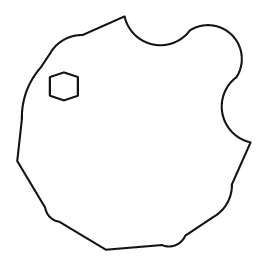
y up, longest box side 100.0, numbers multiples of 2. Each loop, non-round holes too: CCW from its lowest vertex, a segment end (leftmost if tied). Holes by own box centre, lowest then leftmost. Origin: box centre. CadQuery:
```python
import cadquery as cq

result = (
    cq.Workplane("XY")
    .moveTo(-12.0, -50.0)
    .lineTo(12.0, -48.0)
    .threePointArc((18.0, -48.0), (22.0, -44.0))
    .lineTo(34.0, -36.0)
    .threePointArc((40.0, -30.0), (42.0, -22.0))
    .lineTo(50.0, -4.0)
    .threePointArc((38.0, 8.0), (44.0, 24.0))
    .threePointArc((42.0, 42.0), (24.0, 44.0))
    .threePointArc((8.0, 38.0), (-4.0, 50.0))
    .lineTo(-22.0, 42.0)
    .threePointArc((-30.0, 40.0), (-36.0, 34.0))
    .lineTo(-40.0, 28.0)
    .threePointArc((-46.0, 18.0), (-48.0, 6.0))
    .lineTo(-50.0, -12.0)
    .lineTo(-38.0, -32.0)
    .threePointArc((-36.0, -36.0), (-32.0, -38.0))
    .close()
    .moveTo(-30.0, 14.0)
    .lineTo(-24.0, 16.0)
    .lineTo(-24.0, 24.0)
    .lineTo(-30.0, 26.0)
    .lineTo(-36.0, 24.0)
    .lineTo(-36.0, 16.0)
    .close()
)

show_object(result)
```